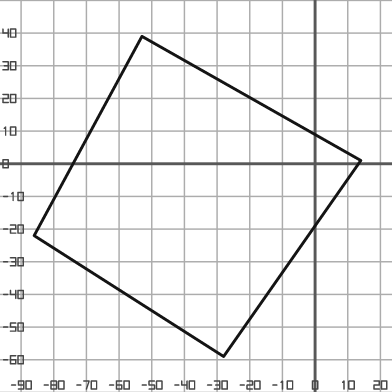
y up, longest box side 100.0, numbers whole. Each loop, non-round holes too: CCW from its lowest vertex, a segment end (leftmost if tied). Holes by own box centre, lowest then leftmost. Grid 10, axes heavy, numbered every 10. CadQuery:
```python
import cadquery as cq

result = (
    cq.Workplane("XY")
    .moveTo(-28.0, -59.0)
    .lineTo(14.0, 1.0)
    .lineTo(-53.0, 39.0)
    .lineTo(-86.0, -22.0)
    .close()
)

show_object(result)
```